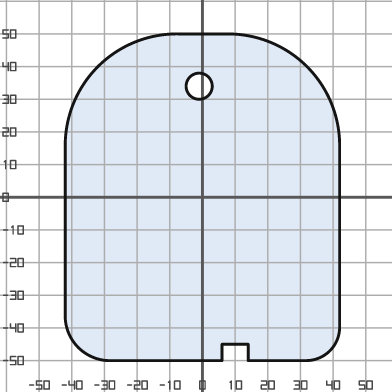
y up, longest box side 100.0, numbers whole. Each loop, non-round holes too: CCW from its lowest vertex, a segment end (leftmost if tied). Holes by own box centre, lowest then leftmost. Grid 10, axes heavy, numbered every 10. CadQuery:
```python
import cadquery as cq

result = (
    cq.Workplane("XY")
    .moveTo(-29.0, -50.0)
    .lineTo(6.0, -50.0)
    .lineTo(6.0, -45.0)
    .lineTo(14.0, -45.0)
    .lineTo(14.0, -50.0)
    .lineTo(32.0, -50.0)
    .threePointArc((39.0, -47.0), (42.0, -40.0))
    .lineTo(42.0, 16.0)
    .threePointArc((32.0, 40.0), (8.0, 50.0))
    .lineTo(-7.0, 50.0)
    .threePointArc((-32.0, 40.0), (-42.0, 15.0))
    .lineTo(-42.0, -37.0)
    .threePointArc((-38.0, -46.0), (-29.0, -50.0))
    .close()
    .moveTo(-1.0, 34.0)
    .circle(4.0)
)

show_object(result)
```